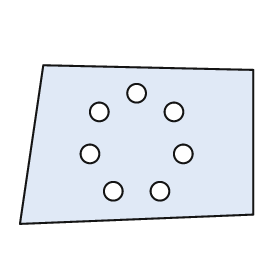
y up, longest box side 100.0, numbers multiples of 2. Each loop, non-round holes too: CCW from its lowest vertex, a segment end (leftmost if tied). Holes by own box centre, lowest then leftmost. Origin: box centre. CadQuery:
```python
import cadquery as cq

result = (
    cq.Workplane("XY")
    .moveTo(-50.0, -34.0)
    .lineTo(50.0, -30.0)
    .lineTo(50.0, 32.0)
    .lineTo(-40.0, 34.0)
    .close()
    .moveTo(-10.0, -20.0)
    .circle(4.0)
    .moveTo(10.0, -20.0)
    .circle(4.0)
    .moveTo(-20.0, -4.0)
    .circle(4.0)
    .moveTo(20.0, -4.0)
    .circle(4.0)
    .moveTo(-16.0, 14.0)
    .circle(4.0)
    .moveTo(16.0, 14.0)
    .circle(4.0)
    .moveTo(0.0, 22.0)
    .circle(4.0)
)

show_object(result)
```